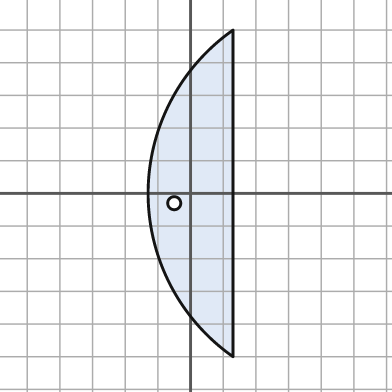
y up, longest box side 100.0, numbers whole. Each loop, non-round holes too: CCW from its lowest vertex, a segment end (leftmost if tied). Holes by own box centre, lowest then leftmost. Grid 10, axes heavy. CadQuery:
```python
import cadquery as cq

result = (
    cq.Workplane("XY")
    .moveTo(13.0, -50.0)
    .lineTo(13.0, 50.0)
    .threePointArc((-13.0, 0.0), (13.0, -50.0))
    .close()
    .moveTo(-5.0, -3.0)
    .circle(2.0)
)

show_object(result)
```